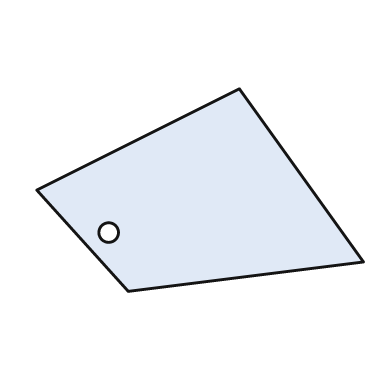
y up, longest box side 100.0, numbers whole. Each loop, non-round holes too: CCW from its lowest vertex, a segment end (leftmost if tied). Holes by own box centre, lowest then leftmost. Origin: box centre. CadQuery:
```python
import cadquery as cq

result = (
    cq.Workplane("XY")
    .moveTo(-22.0, -31.0)
    .lineTo(50.0, -22.0)
    .lineTo(12.0, 31.0)
    .lineTo(-50.0, 0.0)
    .close()
    .moveTo(-28.0, -13.0)
    .circle(3.0)
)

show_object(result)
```